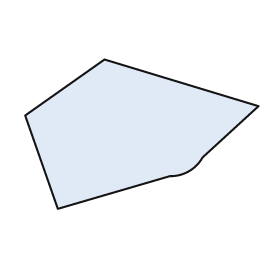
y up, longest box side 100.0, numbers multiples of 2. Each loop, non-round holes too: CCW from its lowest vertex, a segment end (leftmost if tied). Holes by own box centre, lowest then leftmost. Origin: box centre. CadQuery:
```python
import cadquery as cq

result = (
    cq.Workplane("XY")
    .moveTo(-36.0, -32.0)
    .lineTo(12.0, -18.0)
    .threePointArc((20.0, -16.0), (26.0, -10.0))
    .lineTo(50.0, 12.0)
    .lineTo(-16.0, 32.0)
    .lineTo(-50.0, 8.0)
    .close()
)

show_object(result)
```